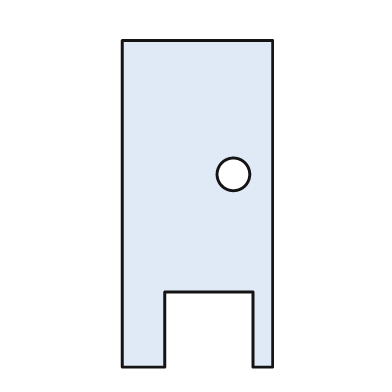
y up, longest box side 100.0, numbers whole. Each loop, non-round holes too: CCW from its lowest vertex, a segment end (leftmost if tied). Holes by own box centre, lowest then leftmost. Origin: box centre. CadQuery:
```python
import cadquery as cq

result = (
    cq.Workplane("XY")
    .moveTo(-23.0, -50.0)
    .lineTo(-10.0, -50.0)
    .lineTo(-10.0, -27.0)
    .lineTo(17.0, -27.0)
    .lineTo(17.0, -50.0)
    .lineTo(23.0, -50.0)
    .lineTo(23.0, 50.0)
    .lineTo(-23.0, 50.0)
    .close()
    .moveTo(11.0, 9.0)
    .circle(5.0)
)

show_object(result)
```